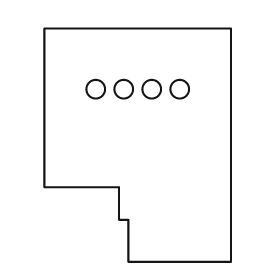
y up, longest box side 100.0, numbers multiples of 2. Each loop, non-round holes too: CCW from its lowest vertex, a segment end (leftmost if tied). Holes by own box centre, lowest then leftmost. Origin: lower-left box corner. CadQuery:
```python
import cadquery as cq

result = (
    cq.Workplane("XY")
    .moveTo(36.0, 0.0)
    .lineTo(80.0, 0.0)
    .lineTo(80.0, 100.0)
    .lineTo(0.0, 100.0)
    .lineTo(0.0, 32.0)
    .lineTo(32.0, 32.0)
    .lineTo(32.0, 18.0)
    .lineTo(36.0, 18.0)
    .close()
    .moveTo(22.0, 74.0)
    .circle(4.0)
    .moveTo(34.0, 74.0)
    .circle(4.0)
    .moveTo(46.0, 74.0)
    .circle(4.0)
    .moveTo(58.0, 74.0)
    .circle(4.0)
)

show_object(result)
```